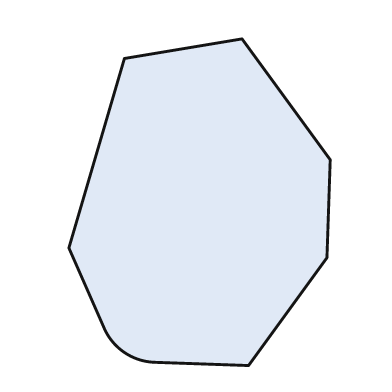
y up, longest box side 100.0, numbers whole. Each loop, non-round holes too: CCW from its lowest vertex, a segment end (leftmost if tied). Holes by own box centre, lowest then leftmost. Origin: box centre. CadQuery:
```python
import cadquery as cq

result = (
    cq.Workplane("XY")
    .moveTo(15.0, -50.0)
    .lineTo(39.0, -17.0)
    .lineTo(40.0, 13.0)
    .lineTo(13.0, 50.0)
    .lineTo(-23.0, 44.0)
    .lineTo(-40.0, -14.0)
    .lineTo(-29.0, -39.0)
    .threePointArc((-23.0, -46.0), (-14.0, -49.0))
    .close()
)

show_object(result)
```